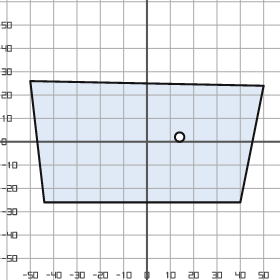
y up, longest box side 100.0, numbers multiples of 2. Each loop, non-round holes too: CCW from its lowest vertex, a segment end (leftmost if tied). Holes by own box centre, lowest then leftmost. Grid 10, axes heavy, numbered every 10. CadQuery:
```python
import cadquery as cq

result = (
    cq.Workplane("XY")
    .moveTo(-44.0, -26.0)
    .lineTo(40.0, -26.0)
    .lineTo(50.0, 24.0)
    .lineTo(-50.0, 26.0)
    .close()
    .moveTo(14.0, 2.0)
    .circle(2.0)
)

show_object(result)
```